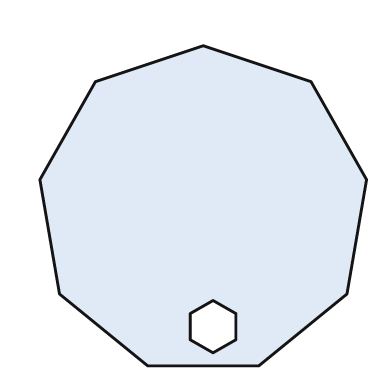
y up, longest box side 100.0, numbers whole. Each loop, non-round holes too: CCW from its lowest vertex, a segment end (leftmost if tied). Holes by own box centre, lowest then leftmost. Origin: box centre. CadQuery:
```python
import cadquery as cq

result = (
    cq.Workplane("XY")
    .moveTo(-17.0, -49.0)
    .lineTo(17.0, -49.0)
    .lineTo(44.0, -27.0)
    .lineTo(50.0, 8.0)
    .lineTo(33.0, 38.0)
    .lineTo(0.0, 49.0)
    .lineTo(-33.0, 38.0)
    .lineTo(-50.0, 8.0)
    .lineTo(-44.0, -27.0)
    .close()
    .moveTo(3.0, -45.0)
    .lineTo(10.0, -41.0)
    .lineTo(10.0, -33.0)
    .lineTo(3.0, -29.0)
    .lineTo(-4.0, -33.0)
    .lineTo(-4.0, -41.0)
    .close()
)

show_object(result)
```